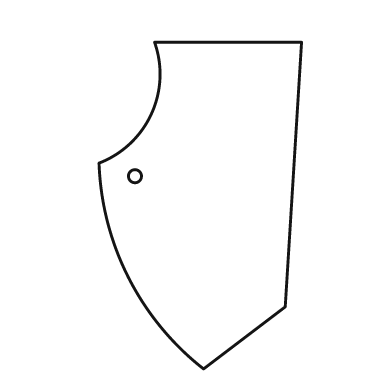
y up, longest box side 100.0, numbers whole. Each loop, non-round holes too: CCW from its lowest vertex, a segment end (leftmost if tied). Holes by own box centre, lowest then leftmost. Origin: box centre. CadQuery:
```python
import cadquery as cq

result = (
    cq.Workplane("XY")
    .moveTo(1.0, -50.0)
    .lineTo(26.0, -31.0)
    .lineTo(31.0, 50.0)
    .lineTo(-14.0, 50.0)
    .threePointArc((-15.0, 28.0), (-31.0, 13.0))
    .threePointArc((-22.0, -22.0), (1.0, -50.0))
    .close()
    .moveTo(-20.0, 9.0)
    .circle(2.0)
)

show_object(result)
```